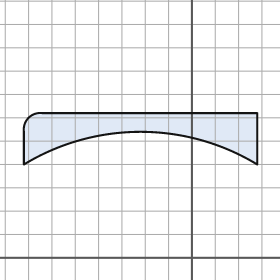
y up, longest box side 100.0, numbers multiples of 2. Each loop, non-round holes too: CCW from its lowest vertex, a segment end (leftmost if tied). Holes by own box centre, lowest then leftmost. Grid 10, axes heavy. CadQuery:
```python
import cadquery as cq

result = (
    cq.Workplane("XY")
    .moveTo(-72.0, 40.0)
    .threePointArc((-22.0, 54.0), (28.0, 40.0))
    .lineTo(28.0, 62.0)
    .lineTo(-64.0, 62.0)
    .threePointArc((-70.0, 60.0), (-72.0, 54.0))
    .close()
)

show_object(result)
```